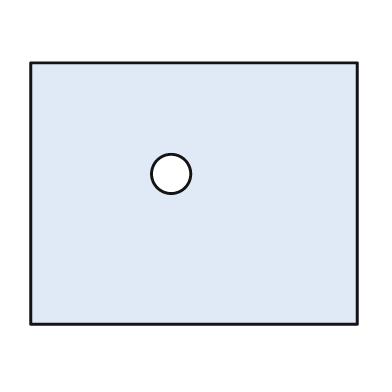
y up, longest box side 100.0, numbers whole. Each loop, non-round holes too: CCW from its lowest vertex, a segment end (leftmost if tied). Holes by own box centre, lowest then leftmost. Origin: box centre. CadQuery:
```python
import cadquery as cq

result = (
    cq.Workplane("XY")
    .moveTo(-50.0, -40.0)
    .lineTo(50.0, -40.0)
    .lineTo(50.0, 40.0)
    .lineTo(-50.0, 40.0)
    .close()
    .moveTo(-7.0, 6.0)
    .circle(6.0)
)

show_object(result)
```